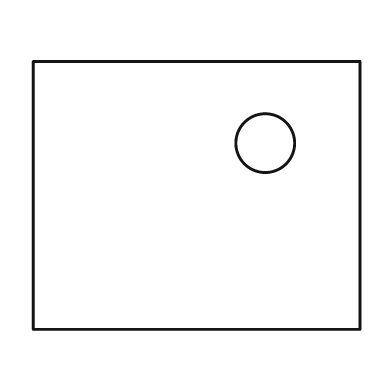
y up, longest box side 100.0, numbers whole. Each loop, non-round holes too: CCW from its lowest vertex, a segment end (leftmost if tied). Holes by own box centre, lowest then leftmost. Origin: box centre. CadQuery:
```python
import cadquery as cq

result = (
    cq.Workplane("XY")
    .moveTo(-50.0, -41.0)
    .lineTo(50.0, -41.0)
    .lineTo(50.0, 41.0)
    .lineTo(-50.0, 41.0)
    .close()
    .moveTo(21.0, 16.0)
    .circle(9.0)
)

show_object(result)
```